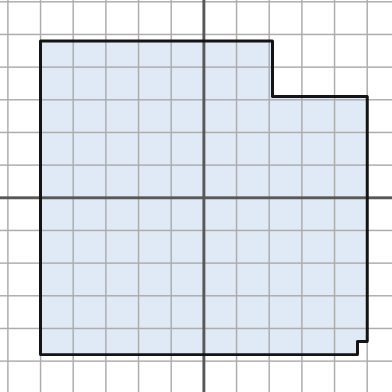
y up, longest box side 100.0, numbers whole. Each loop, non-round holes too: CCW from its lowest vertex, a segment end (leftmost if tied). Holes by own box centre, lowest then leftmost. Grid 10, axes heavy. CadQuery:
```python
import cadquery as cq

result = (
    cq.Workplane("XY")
    .moveTo(-50.0, -48.0)
    .lineTo(47.0, -48.0)
    .lineTo(47.0, -44.0)
    .lineTo(50.0, -44.0)
    .lineTo(50.0, 31.0)
    .lineTo(21.0, 31.0)
    .lineTo(21.0, 48.0)
    .lineTo(-50.0, 48.0)
    .close()
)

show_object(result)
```